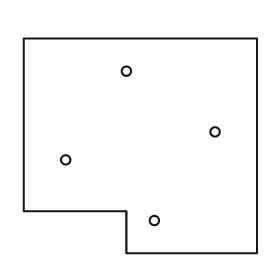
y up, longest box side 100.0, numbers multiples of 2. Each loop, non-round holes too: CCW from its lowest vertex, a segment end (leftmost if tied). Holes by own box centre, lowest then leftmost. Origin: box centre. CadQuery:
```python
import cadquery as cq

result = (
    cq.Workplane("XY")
    .moveTo(-6.0, -46.0)
    .lineTo(50.0, -46.0)
    .lineTo(50.0, 46.0)
    .lineTo(-50.0, 46.0)
    .lineTo(-50.0, -28.0)
    .lineTo(-6.0, -28.0)
    .close()
    .moveTo(6.0, -32.0)
    .circle(2.0)
    .moveTo(-32.0, -6.0)
    .circle(2.0)
    .moveTo(32.0, 6.0)
    .circle(2.0)
    .moveTo(-6.0, 32.0)
    .circle(2.0)
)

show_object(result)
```